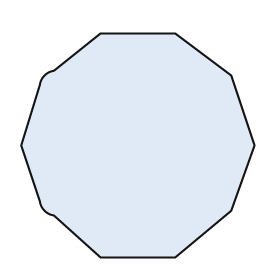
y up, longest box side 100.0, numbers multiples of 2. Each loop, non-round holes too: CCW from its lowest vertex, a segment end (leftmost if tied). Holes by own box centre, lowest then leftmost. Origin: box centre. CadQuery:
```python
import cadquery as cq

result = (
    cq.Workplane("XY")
    .moveTo(-16.0, -48.0)
    .lineTo(16.0, -48.0)
    .lineTo(40.0, -28.0)
    .lineTo(50.0, 0.0)
    .lineTo(40.0, 30.0)
    .lineTo(16.0, 48.0)
    .lineTo(-16.0, 48.0)
    .lineTo(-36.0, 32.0)
    .threePointArc((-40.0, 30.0), (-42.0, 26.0))
    .lineTo(-50.0, 0.0)
    .lineTo(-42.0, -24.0)
    .threePointArc((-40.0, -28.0), (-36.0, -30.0))
    .close()
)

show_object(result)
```